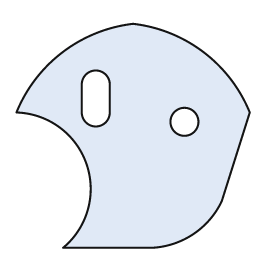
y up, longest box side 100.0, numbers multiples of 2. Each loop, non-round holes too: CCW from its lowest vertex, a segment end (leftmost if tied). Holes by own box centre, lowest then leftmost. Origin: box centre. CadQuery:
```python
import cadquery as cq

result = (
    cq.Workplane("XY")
    .moveTo(-30.0, -48.0)
    .lineTo(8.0, -48.0)
    .threePointArc((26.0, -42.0), (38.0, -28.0))
    .lineTo(50.0, 10.0)
    .threePointArc((30.0, 36.0), (0.0, 48.0))
    .threePointArc((-30.0, 36.0), (-50.0, 10.0))
    .threePointArc((-20.0, -12.0), (-30.0, -48.0))
    .close()
    .moveTo(22.0, 6.0)
    .circle(6.0)
    .moveTo(-22.0, 10.0)
    .threePointArc((-16.0, 4.0), (-10.0, 10.0))
    .lineTo(-10.0, 22.0)
    .threePointArc((-16.0, 28.0), (-22.0, 22.0))
    .close()
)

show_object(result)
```